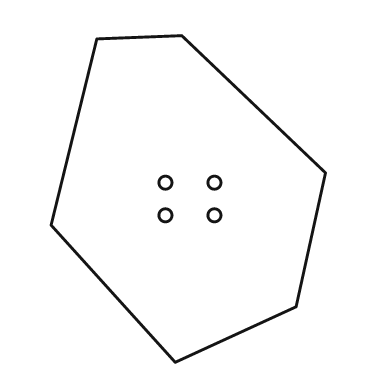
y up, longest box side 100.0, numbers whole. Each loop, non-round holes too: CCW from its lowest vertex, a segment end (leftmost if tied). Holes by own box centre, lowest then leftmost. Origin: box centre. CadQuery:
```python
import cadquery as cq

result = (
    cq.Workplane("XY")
    .moveTo(-4.0, -50.0)
    .lineTo(33.0, -33.0)
    .lineTo(42.0, 8.0)
    .lineTo(-2.0, 50.0)
    .lineTo(-28.0, 49.0)
    .lineTo(-42.0, -8.0)
    .close()
    .moveTo(-7.0, -5.0)
    .circle(2.0)
    .moveTo(8.0, -5.0)
    .circle(2.0)
    .moveTo(-7.0, 5.0)
    .circle(2.0)
    .moveTo(8.0, 5.0)
    .circle(2.0)
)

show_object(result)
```